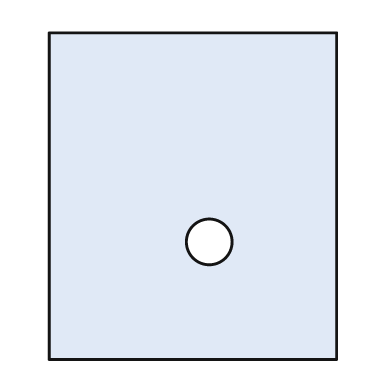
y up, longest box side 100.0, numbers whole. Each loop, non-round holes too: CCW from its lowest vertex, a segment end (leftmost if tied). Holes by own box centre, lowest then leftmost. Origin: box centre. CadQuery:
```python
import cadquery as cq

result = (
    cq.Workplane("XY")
    .moveTo(-44.0, -50.0)
    .lineTo(44.0, -50.0)
    .lineTo(44.0, 50.0)
    .lineTo(-44.0, 50.0)
    .close()
    .moveTo(5.0, -14.0)
    .circle(7.0)
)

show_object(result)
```